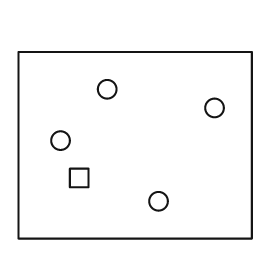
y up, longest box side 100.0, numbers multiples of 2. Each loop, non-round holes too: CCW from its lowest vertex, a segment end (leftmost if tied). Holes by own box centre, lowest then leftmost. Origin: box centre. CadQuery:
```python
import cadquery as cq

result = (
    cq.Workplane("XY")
    .moveTo(-50.0, -40.0)
    .lineTo(50.0, -40.0)
    .lineTo(50.0, 40.0)
    .lineTo(-50.0, 40.0)
    .close()
    .moveTo(10.0, -24.0)
    .circle(4.0)
    .moveTo(-28.0, -18.0)
    .lineTo(-20.0, -18.0)
    .lineTo(-20.0, -10.0)
    .lineTo(-28.0, -10.0)
    .close()
    .moveTo(-32.0, 2.0)
    .circle(4.0)
    .moveTo(34.0, 16.0)
    .circle(4.0)
    .moveTo(-12.0, 24.0)
    .circle(4.0)
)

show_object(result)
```